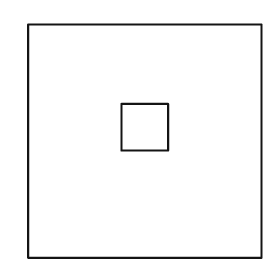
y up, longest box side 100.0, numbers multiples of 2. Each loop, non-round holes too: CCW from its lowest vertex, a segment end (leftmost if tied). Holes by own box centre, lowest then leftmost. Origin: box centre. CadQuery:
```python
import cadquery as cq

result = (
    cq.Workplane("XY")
    .moveTo(-50.0, -50.0)
    .lineTo(50.0, -50.0)
    .lineTo(50.0, 50.0)
    .lineTo(-50.0, 50.0)
    .close()
    .moveTo(-10.0, -4.0)
    .lineTo(10.0, -4.0)
    .lineTo(10.0, 16.0)
    .lineTo(-10.0, 16.0)
    .close()
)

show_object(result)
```